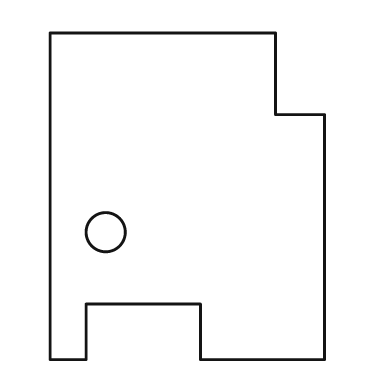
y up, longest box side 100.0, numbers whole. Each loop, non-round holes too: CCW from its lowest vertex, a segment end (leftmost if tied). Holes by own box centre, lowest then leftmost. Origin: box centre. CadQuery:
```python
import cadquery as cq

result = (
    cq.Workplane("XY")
    .moveTo(-42.0, -50.0)
    .lineTo(-31.0, -50.0)
    .lineTo(-31.0, -33.0)
    .lineTo(4.0, -33.0)
    .lineTo(4.0, -50.0)
    .lineTo(42.0, -50.0)
    .lineTo(42.0, 25.0)
    .lineTo(27.0, 25.0)
    .lineTo(27.0, 50.0)
    .lineTo(-42.0, 50.0)
    .close()
    .moveTo(-25.0, -11.0)
    .circle(6.0)
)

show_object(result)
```